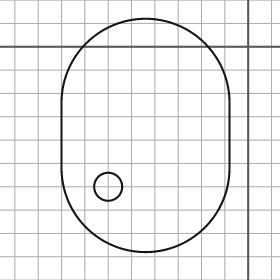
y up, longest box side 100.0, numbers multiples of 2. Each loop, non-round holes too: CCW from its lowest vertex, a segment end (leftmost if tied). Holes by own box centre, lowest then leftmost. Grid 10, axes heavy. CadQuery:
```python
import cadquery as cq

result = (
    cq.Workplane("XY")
    .moveTo(-80.0, -52.0)
    .threePointArc((-44.0, -88.0), (-8.0, -52.0))
    .lineTo(-8.0, -24.0)
    .threePointArc((-44.0, 12.0), (-80.0, -24.0))
    .close()
    .moveTo(-60.0, -60.0)
    .circle(6.0)
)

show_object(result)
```